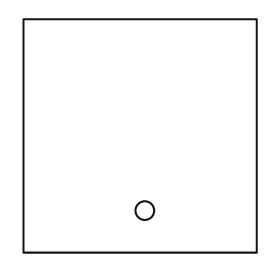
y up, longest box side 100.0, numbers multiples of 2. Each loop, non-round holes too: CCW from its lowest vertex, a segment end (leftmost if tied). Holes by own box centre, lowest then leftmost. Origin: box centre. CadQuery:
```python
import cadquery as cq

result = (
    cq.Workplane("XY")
    .moveTo(-50.0, -50.0)
    .lineTo(50.0, -50.0)
    .lineTo(50.0, 50.0)
    .lineTo(-50.0, 50.0)
    .close()
    .moveTo(2.0, -32.0)
    .circle(4.0)
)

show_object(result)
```